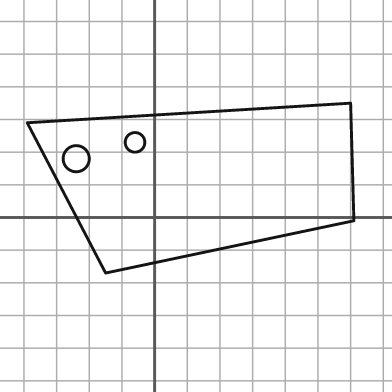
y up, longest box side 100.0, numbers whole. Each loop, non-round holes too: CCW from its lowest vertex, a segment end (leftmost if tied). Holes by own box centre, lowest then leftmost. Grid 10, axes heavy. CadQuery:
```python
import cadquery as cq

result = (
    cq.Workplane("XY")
    .moveTo(-15.0, -17.0)
    .lineTo(61.0, -1.0)
    .lineTo(60.0, 35.0)
    .lineTo(-39.0, 29.0)
    .close()
    .moveTo(-24.0, 18.0)
    .circle(4.0)
    .moveTo(-6.0, 23.0)
    .circle(3.0)
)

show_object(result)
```